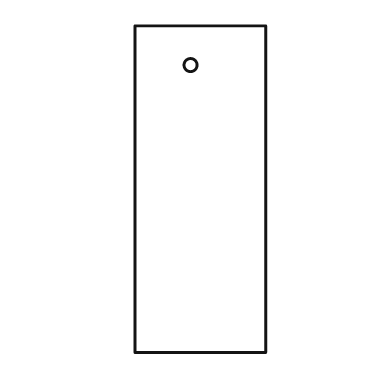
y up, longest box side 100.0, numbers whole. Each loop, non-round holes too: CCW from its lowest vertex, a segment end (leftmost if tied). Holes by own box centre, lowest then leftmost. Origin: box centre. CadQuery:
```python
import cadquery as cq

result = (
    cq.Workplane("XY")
    .moveTo(-20.0, -50.0)
    .lineTo(20.0, -50.0)
    .lineTo(20.0, 50.0)
    .lineTo(-20.0, 50.0)
    .close()
    .moveTo(-3.0, 38.0)
    .circle(2.0)
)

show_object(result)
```